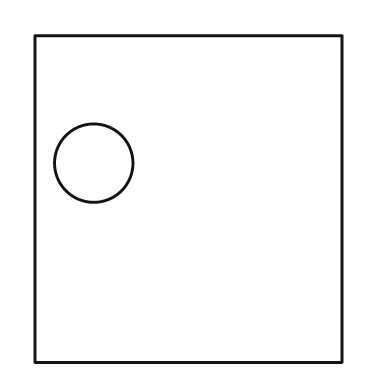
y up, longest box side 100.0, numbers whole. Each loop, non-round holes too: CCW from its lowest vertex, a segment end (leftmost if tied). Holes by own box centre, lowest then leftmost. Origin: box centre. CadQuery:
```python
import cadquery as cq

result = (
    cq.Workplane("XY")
    .moveTo(-47.0, -50.0)
    .lineTo(47.0, -50.0)
    .lineTo(47.0, 50.0)
    .lineTo(-47.0, 50.0)
    .close()
    .moveTo(-29.0, 11.0)
    .circle(12.0)
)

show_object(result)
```